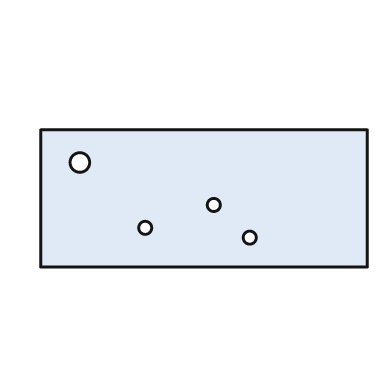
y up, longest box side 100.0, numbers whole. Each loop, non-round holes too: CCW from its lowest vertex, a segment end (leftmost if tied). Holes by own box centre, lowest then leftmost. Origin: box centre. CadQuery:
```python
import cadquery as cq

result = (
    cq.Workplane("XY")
    .moveTo(-50.0, -21.0)
    .lineTo(50.0, -21.0)
    .lineTo(50.0, 21.0)
    .lineTo(-50.0, 21.0)
    .close()
    .moveTo(14.0, -12.0)
    .circle(2.0)
    .moveTo(-18.0, -9.0)
    .circle(2.0)
    .moveTo(3.0, -2.0)
    .circle(2.0)
    .moveTo(-38.0, 11.0)
    .circle(3.0)
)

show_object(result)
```